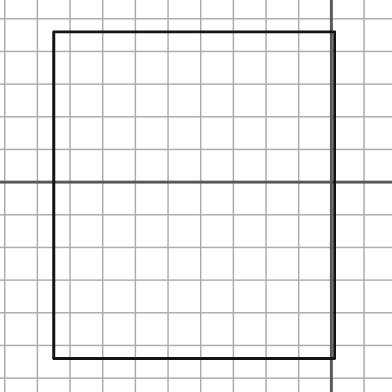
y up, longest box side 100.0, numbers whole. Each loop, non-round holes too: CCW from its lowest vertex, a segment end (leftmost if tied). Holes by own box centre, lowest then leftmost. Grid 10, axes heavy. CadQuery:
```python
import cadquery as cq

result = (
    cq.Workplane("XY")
    .moveTo(-85.0, -54.0)
    .lineTo(1.0, -54.0)
    .lineTo(1.0, 46.0)
    .lineTo(-85.0, 46.0)
    .close()
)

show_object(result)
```